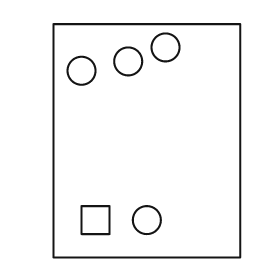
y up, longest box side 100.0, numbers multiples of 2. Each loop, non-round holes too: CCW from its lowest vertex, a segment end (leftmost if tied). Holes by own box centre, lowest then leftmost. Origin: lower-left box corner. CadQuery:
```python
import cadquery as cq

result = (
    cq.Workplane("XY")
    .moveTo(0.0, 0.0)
    .lineTo(80.0, 0.0)
    .lineTo(80.0, 100.0)
    .lineTo(0.0, 100.0)
    .close()
    .moveTo(12.0, 10.0)
    .lineTo(24.0, 10.0)
    .lineTo(24.0, 22.0)
    .lineTo(12.0, 22.0)
    .close()
    .moveTo(40.0, 16.0)
    .circle(6.0)
    .moveTo(12.0, 80.0)
    .circle(6.0)
    .moveTo(32.0, 84.0)
    .circle(6.0)
    .moveTo(48.0, 90.0)
    .circle(6.0)
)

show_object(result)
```